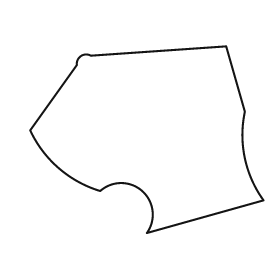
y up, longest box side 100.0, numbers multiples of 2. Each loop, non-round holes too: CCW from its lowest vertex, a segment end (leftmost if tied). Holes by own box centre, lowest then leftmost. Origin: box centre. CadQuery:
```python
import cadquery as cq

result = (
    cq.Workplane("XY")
    .moveTo(0.0, -40.0)
    .lineTo(50.0, -26.0)
    .threePointArc((42.0, -8.0), (42.0, 12.0))
    .lineTo(34.0, 40.0)
    .lineTo(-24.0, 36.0)
    .threePointArc((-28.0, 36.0), (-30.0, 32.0))
    .lineTo(-50.0, 4.0)
    .threePointArc((-38.0, -12.0), (-20.0, -22.0))
    .threePointArc((-2.0, -22.0), (0.0, -40.0))
    .close()
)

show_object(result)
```